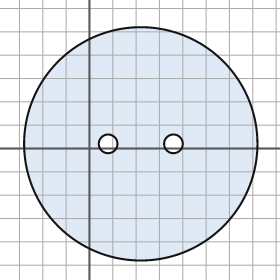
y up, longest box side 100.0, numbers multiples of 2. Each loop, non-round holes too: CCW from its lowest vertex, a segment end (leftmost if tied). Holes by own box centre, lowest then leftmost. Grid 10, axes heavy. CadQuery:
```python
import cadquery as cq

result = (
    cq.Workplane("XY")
    .moveTo(22.0, 2.0)
    .circle(50.0)
    .moveTo(8.0, 2.0)
    .circle(4.0)
    .moveTo(36.0, 2.0)
    .circle(4.0)
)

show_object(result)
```